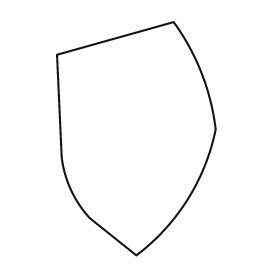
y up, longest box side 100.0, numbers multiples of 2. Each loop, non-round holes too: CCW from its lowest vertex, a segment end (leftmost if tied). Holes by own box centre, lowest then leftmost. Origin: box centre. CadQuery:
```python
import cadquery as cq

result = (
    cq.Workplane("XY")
    .moveTo(0.0, -50.0)
    .threePointArc((22.0, -26.0), (34.0, 4.0))
    .threePointArc((28.0, 28.0), (16.0, 50.0))
    .lineTo(-34.0, 36.0)
    .lineTo(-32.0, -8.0)
    .threePointArc((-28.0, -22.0), (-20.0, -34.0))
    .close()
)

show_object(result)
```